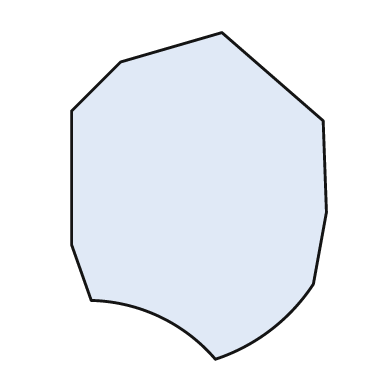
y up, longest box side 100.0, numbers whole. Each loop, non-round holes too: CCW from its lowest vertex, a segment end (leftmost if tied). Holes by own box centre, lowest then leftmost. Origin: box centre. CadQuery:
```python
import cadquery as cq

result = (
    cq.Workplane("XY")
    .moveTo(5.0, -50.0)
    .threePointArc((22.0, -41.0), (35.0, -27.0))
    .lineTo(39.0, -5.0)
    .lineTo(38.0, 23.0)
    .lineTo(7.0, 50.0)
    .lineTo(-24.0, 41.0)
    .lineTo(-39.0, 26.0)
    .lineTo(-39.0, -15.0)
    .lineTo(-33.0, -32.0)
    .threePointArc((-12.0, -37.0), (5.0, -50.0))
    .close()
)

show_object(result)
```